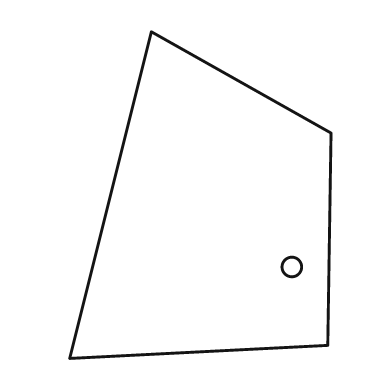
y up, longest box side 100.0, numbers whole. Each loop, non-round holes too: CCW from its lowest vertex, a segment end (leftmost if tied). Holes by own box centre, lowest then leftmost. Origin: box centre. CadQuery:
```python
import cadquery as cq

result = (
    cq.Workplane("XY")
    .moveTo(-40.0, -50.0)
    .lineTo(39.0, -46.0)
    .lineTo(40.0, 19.0)
    .lineTo(-15.0, 50.0)
    .close()
    .moveTo(28.0, -22.0)
    .circle(3.0)
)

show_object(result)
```